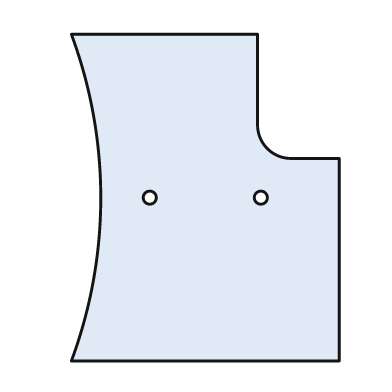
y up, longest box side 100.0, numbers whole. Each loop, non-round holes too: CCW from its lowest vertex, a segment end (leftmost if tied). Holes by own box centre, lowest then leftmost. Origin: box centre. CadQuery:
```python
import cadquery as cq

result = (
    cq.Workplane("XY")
    .moveTo(-41.0, -50.0)
    .lineTo(41.0, -50.0)
    .lineTo(41.0, 12.0)
    .lineTo(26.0, 12.0)
    .threePointArc((19.0, 15.0), (16.0, 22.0))
    .lineTo(16.0, 50.0)
    .lineTo(-41.0, 50.0)
    .threePointArc((-32.0, 0.0), (-41.0, -50.0))
    .close()
    .moveTo(-17.0, 0.0)
    .circle(2.0)
    .moveTo(17.0, 0.0)
    .circle(2.0)
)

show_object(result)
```